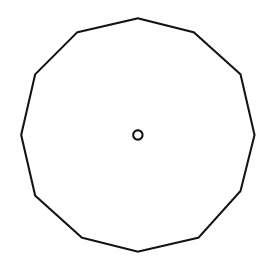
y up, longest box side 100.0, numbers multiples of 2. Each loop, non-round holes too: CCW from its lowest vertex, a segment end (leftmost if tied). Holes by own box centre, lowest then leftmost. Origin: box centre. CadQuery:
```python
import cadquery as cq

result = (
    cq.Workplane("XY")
    .moveTo(0.0, -50.0)
    .lineTo(26.0, -44.0)
    .lineTo(44.0, -24.0)
    .lineTo(50.0, 0.0)
    .lineTo(44.0, 26.0)
    .lineTo(24.0, 44.0)
    .lineTo(0.0, 50.0)
    .lineTo(-26.0, 44.0)
    .lineTo(-44.0, 26.0)
    .lineTo(-50.0, 0.0)
    .lineTo(-44.0, -26.0)
    .lineTo(-24.0, -44.0)
    .close()
    .moveTo(0.0, 0.0)
    .circle(2.0)
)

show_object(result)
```